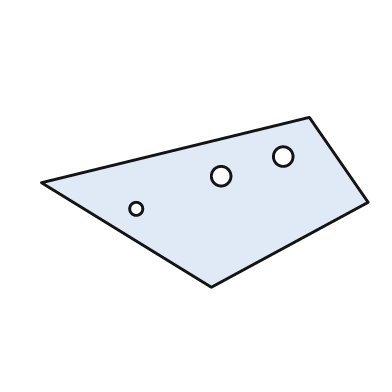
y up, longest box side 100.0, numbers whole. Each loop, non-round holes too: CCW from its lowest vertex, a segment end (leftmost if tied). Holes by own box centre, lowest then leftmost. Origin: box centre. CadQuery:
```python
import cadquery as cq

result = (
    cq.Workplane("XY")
    .moveTo(2.0, -26.0)
    .lineTo(50.0, 0.0)
    .lineTo(32.0, 26.0)
    .lineTo(-50.0, 6.0)
    .close()
    .moveTo(-21.0, -2.0)
    .circle(2.0)
    .moveTo(5.0, 8.0)
    .circle(3.0)
    .moveTo(24.0, 14.0)
    .circle(3.0)
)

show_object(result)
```